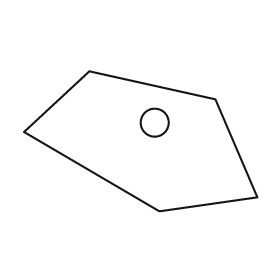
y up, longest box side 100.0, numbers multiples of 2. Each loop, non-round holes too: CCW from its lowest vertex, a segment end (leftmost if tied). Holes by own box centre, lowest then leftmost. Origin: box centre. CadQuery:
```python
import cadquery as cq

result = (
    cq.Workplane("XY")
    .moveTo(8.0, -30.0)
    .lineTo(50.0, -24.0)
    .lineTo(32.0, 18.0)
    .lineTo(-22.0, 30.0)
    .lineTo(-50.0, 4.0)
    .close()
    .moveTo(6.0, 8.0)
    .circle(6.0)
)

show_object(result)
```